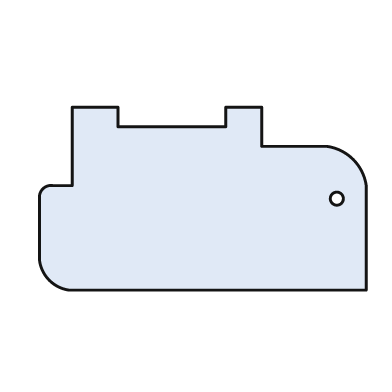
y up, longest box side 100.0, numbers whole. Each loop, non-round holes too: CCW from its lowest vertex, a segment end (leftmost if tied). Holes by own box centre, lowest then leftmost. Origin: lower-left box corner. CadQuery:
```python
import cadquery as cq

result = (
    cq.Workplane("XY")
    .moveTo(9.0, 0.0)
    .lineTo(100.0, 0.0)
    .lineTo(100.0, 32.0)
    .threePointArc((96.0, 40.0), (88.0, 44.0))
    .lineTo(68.0, 44.0)
    .lineTo(68.0, 56.0)
    .lineTo(57.0, 56.0)
    .lineTo(57.0, 50.0)
    .lineTo(24.0, 50.0)
    .lineTo(24.0, 56.0)
    .lineTo(10.0, 56.0)
    .lineTo(10.0, 32.0)
    .lineTo(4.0, 32.0)
    .threePointArc((1.0, 31.0), (0.0, 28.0))
    .lineTo(0.0, 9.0)
    .threePointArc((3.0, 3.0), (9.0, 0.0))
    .close()
    .moveTo(91.0, 28.0)
    .circle(2.0)
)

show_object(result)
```